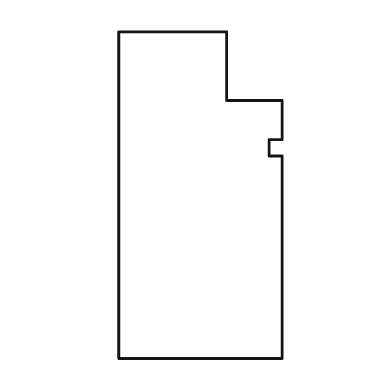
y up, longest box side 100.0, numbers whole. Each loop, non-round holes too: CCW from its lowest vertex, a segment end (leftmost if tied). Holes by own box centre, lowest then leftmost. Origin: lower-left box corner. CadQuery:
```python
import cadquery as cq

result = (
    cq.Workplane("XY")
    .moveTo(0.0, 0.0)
    .lineTo(50.0, 0.0)
    .lineTo(50.0, 62.0)
    .lineTo(46.0, 62.0)
    .lineTo(46.0, 67.0)
    .lineTo(50.0, 67.0)
    .lineTo(50.0, 79.0)
    .lineTo(33.0, 79.0)
    .lineTo(33.0, 100.0)
    .lineTo(0.0, 100.0)
    .close()
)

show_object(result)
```